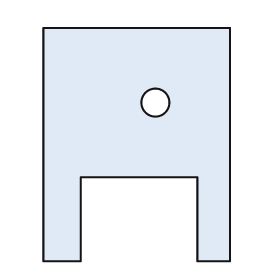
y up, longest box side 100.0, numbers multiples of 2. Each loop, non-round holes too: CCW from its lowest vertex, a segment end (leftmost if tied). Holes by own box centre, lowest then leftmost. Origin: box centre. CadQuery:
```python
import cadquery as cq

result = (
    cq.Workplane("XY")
    .moveTo(-40.0, -50.0)
    .lineTo(-24.0, -50.0)
    .lineTo(-24.0, -14.0)
    .lineTo(26.0, -14.0)
    .lineTo(26.0, -50.0)
    .lineTo(40.0, -50.0)
    .lineTo(40.0, 50.0)
    .lineTo(-40.0, 50.0)
    .close()
    .moveTo(8.0, 18.0)
    .circle(6.0)
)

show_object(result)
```